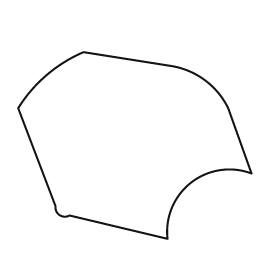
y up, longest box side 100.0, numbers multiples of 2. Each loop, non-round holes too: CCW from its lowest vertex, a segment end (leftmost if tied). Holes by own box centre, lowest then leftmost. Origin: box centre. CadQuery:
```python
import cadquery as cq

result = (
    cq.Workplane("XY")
    .moveTo(14.0, -40.0)
    .threePointArc((24.0, -16.0), (50.0, -12.0))
    .lineTo(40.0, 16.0)
    .threePointArc((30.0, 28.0), (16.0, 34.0))
    .lineTo(-22.0, 40.0)
    .threePointArc((-38.0, 30.0), (-50.0, 16.0))
    .lineTo(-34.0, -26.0)
    .threePointArc((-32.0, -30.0), (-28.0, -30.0))
    .close()
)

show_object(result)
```